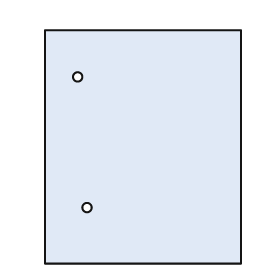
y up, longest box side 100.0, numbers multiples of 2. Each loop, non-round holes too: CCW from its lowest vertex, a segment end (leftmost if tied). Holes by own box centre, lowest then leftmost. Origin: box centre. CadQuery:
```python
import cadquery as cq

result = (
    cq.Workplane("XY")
    .moveTo(-42.0, -50.0)
    .lineTo(42.0, -50.0)
    .lineTo(42.0, 50.0)
    .lineTo(-42.0, 50.0)
    .close()
    .moveTo(-24.0, -26.0)
    .circle(2.0)
    .moveTo(-28.0, 30.0)
    .circle(2.0)
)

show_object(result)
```